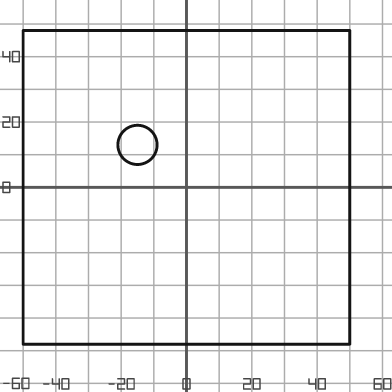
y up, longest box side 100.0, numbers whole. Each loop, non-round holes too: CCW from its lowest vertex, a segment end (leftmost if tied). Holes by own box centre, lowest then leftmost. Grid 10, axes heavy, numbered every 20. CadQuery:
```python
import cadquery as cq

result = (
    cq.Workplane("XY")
    .moveTo(-50.0, -48.0)
    .lineTo(50.0, -48.0)
    .lineTo(50.0, 48.0)
    .lineTo(-50.0, 48.0)
    .close()
    .moveTo(-15.0, 13.0)
    .circle(6.0)
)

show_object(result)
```